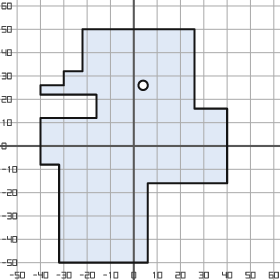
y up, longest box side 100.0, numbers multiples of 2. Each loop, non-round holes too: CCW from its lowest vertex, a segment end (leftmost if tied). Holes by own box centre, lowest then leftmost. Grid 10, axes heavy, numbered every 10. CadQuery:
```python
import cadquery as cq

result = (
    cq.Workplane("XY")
    .moveTo(-32.0, -50.0)
    .lineTo(6.0, -50.0)
    .lineTo(6.0, -16.0)
    .lineTo(40.0, -16.0)
    .lineTo(40.0, 16.0)
    .lineTo(26.0, 16.0)
    .lineTo(26.0, 50.0)
    .lineTo(-22.0, 50.0)
    .lineTo(-22.0, 32.0)
    .lineTo(-30.0, 32.0)
    .lineTo(-30.0, 26.0)
    .lineTo(-40.0, 26.0)
    .lineTo(-40.0, 22.0)
    .lineTo(-16.0, 22.0)
    .lineTo(-16.0, 12.0)
    .lineTo(-40.0, 12.0)
    .lineTo(-40.0, -8.0)
    .lineTo(-32.0, -8.0)
    .close()
    .moveTo(4.0, 26.0)
    .circle(2.0)
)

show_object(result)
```